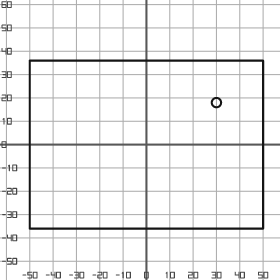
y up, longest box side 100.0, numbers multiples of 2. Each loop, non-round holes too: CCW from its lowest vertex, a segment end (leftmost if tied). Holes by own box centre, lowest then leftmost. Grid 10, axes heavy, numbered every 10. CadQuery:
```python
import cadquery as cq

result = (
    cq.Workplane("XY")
    .moveTo(-50.0, -36.0)
    .lineTo(50.0, -36.0)
    .lineTo(50.0, 36.0)
    .lineTo(-50.0, 36.0)
    .close()
    .moveTo(30.0, 18.0)
    .circle(2.0)
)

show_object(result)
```